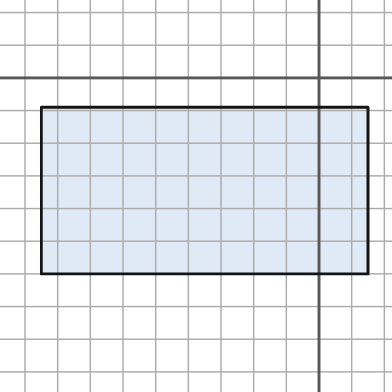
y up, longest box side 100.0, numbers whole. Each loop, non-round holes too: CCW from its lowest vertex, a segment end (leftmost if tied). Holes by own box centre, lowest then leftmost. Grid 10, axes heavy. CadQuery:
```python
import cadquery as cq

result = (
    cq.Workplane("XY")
    .moveTo(-85.0, -60.0)
    .lineTo(15.0, -60.0)
    .lineTo(15.0, -9.0)
    .lineTo(-85.0, -9.0)
    .close()
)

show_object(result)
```